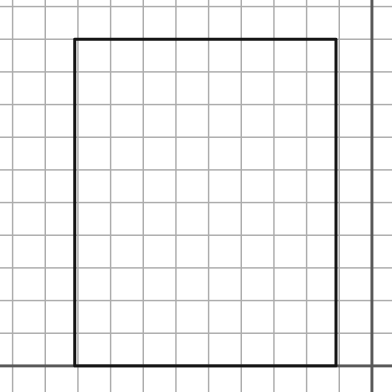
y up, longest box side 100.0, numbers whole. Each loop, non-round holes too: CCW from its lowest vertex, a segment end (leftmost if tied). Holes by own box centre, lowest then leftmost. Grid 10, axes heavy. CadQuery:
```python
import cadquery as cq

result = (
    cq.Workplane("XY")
    .moveTo(-91.0, 0.0)
    .lineTo(-11.0, 0.0)
    .lineTo(-11.0, 100.0)
    .lineTo(-91.0, 100.0)
    .close()
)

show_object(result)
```